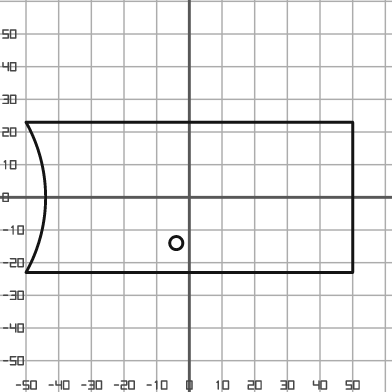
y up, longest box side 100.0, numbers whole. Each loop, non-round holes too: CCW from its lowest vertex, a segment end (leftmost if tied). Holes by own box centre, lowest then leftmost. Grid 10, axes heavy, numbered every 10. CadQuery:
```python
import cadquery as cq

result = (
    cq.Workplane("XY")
    .moveTo(-50.0, -23.0)
    .lineTo(50.0, -23.0)
    .lineTo(50.0, 23.0)
    .lineTo(-50.0, 23.0)
    .threePointArc((-44.0, 0.0), (-50.0, -23.0))
    .close()
    .moveTo(-4.0, -14.0)
    .circle(2.0)
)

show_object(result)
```